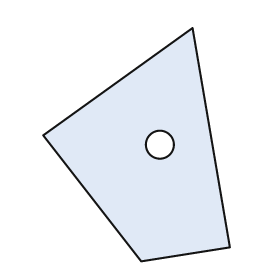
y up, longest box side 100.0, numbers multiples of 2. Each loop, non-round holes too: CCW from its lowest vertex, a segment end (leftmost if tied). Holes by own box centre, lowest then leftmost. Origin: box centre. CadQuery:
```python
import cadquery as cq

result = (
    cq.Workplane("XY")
    .moveTo(2.0, -50.0)
    .lineTo(40.0, -44.0)
    .lineTo(24.0, 50.0)
    .lineTo(-40.0, 4.0)
    .close()
    .moveTo(10.0, 0.0)
    .circle(6.0)
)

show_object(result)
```